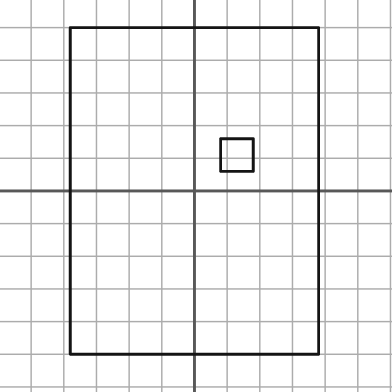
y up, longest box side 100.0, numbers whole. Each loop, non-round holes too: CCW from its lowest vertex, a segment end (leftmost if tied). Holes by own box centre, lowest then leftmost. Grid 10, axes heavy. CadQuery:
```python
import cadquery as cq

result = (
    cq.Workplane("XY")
    .moveTo(-38.0, -50.0)
    .lineTo(38.0, -50.0)
    .lineTo(38.0, 50.0)
    .lineTo(-38.0, 50.0)
    .close()
    .moveTo(8.0, 6.0)
    .lineTo(18.0, 6.0)
    .lineTo(18.0, 16.0)
    .lineTo(8.0, 16.0)
    .close()
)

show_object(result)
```